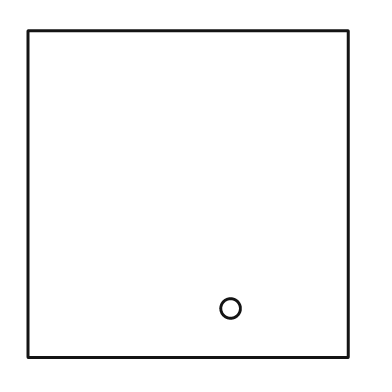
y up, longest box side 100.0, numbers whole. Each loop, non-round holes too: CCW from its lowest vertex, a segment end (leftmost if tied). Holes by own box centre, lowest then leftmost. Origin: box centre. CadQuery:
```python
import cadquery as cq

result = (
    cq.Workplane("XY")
    .moveTo(-49.0, -50.0)
    .lineTo(49.0, -50.0)
    .lineTo(49.0, 50.0)
    .lineTo(-49.0, 50.0)
    .close()
    .moveTo(13.0, -35.0)
    .circle(3.0)
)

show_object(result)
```